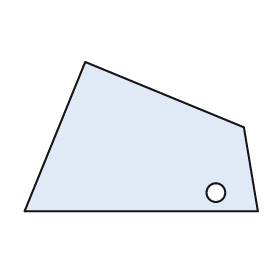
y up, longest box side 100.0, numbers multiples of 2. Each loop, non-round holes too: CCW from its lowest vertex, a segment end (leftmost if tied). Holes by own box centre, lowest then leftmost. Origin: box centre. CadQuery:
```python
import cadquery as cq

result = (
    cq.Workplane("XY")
    .moveTo(-50.0, -32.0)
    .lineTo(50.0, -32.0)
    .lineTo(44.0, 4.0)
    .lineTo(-24.0, 32.0)
    .close()
    .moveTo(32.0, -24.0)
    .circle(4.0)
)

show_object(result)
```